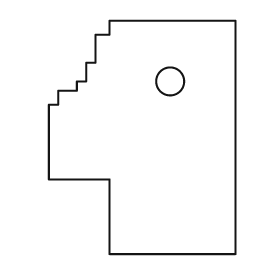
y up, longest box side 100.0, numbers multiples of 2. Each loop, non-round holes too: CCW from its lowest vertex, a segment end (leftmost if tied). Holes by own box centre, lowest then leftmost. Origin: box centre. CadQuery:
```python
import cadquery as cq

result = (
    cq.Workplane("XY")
    .moveTo(-14.0, -50.0)
    .lineTo(40.0, -50.0)
    .lineTo(40.0, 50.0)
    .lineTo(-14.0, 50.0)
    .lineTo(-14.0, 44.0)
    .lineTo(-20.0, 44.0)
    .lineTo(-20.0, 32.0)
    .lineTo(-24.0, 32.0)
    .lineTo(-24.0, 24.0)
    .lineTo(-28.0, 24.0)
    .lineTo(-28.0, 20.0)
    .lineTo(-36.0, 20.0)
    .lineTo(-36.0, 14.0)
    .lineTo(-40.0, 14.0)
    .lineTo(-40.0, -18.0)
    .lineTo(-14.0, -18.0)
    .close()
    .moveTo(12.0, 24.0)
    .circle(6.0)
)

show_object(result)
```